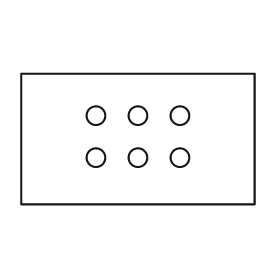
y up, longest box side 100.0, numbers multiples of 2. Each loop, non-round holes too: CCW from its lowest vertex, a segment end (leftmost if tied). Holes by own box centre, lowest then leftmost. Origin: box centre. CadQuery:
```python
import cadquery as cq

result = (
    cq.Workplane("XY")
    .moveTo(-50.0, -28.0)
    .lineTo(50.0, -28.0)
    .lineTo(50.0, 28.0)
    .lineTo(-50.0, 28.0)
    .close()
    .moveTo(-18.0, -8.0)
    .circle(4.0)
    .moveTo(0.0, -8.0)
    .circle(4.0)
    .moveTo(18.0, -8.0)
    .circle(4.0)
    .moveTo(-18.0, 10.0)
    .circle(4.0)
    .moveTo(0.0, 10.0)
    .circle(4.0)
    .moveTo(18.0, 10.0)
    .circle(4.0)
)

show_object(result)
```